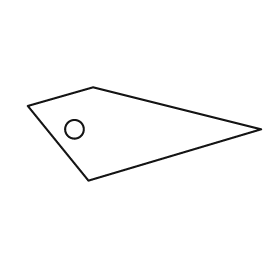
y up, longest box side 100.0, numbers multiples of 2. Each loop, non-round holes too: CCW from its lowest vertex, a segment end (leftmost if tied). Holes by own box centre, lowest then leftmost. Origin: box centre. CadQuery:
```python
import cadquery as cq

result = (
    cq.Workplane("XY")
    .moveTo(-24.0, -20.0)
    .lineTo(50.0, 2.0)
    .lineTo(-22.0, 20.0)
    .lineTo(-50.0, 12.0)
    .close()
    .moveTo(-30.0, 2.0)
    .circle(4.0)
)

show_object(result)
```